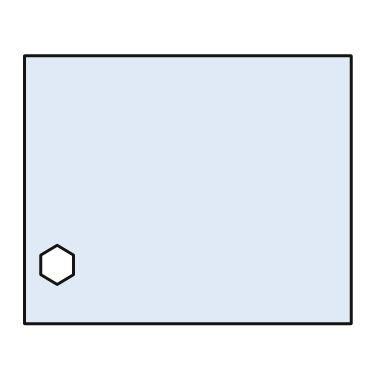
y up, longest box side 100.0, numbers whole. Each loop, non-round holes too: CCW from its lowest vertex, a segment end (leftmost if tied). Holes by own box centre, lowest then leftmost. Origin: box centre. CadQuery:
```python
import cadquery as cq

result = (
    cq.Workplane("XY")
    .moveTo(-50.0, -41.0)
    .lineTo(50.0, -41.0)
    .lineTo(50.0, 41.0)
    .lineTo(-50.0, 41.0)
    .close()
    .moveTo(-40.0, -29.0)
    .lineTo(-35.0, -26.0)
    .lineTo(-35.0, -20.0)
    .lineTo(-40.0, -17.0)
    .lineTo(-45.0, -20.0)
    .lineTo(-45.0, -26.0)
    .close()
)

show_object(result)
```